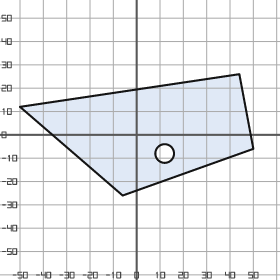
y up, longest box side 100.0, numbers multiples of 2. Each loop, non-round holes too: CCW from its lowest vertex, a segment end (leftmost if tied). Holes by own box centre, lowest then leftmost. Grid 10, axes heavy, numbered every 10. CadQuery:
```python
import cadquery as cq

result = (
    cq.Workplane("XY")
    .moveTo(-6.0, -26.0)
    .lineTo(50.0, -6.0)
    .lineTo(44.0, 26.0)
    .lineTo(-50.0, 12.0)
    .close()
    .moveTo(12.0, -8.0)
    .circle(4.0)
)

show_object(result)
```